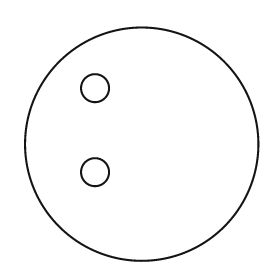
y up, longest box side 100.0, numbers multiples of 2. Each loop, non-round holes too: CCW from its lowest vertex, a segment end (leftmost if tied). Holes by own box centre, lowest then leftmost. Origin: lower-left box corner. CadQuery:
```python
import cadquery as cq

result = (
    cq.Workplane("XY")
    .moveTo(50.0, 50.0)
    .circle(50.0)
    .moveTo(30.0, 38.0)
    .circle(6.0)
    .moveTo(30.0, 74.0)
    .circle(6.0)
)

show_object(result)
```